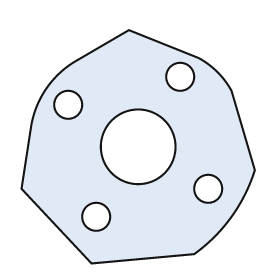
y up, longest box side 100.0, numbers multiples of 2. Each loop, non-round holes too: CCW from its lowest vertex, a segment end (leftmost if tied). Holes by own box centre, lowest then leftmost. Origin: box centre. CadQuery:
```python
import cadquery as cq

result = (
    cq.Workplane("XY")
    .moveTo(-20.0, -50.0)
    .lineTo(24.0, -46.0)
    .threePointArc((40.0, -30.0), (50.0, -10.0))
    .lineTo(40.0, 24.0)
    .threePointArc((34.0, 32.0), (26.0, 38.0))
    .lineTo(-4.0, 50.0)
    .lineTo(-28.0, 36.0)
    .threePointArc((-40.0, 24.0), (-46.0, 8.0))
    .lineTo(-50.0, -18.0)
    .close()
    .moveTo(-18.0, -30.0)
    .circle(6.0)
    .moveTo(30.0, -18.0)
    .circle(6.0)
    .moveTo(0.0, 0.0)
    .circle(16.0)
    .moveTo(-30.0, 18.0)
    .circle(6.0)
    .moveTo(18.0, 30.0)
    .circle(6.0)
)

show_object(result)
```